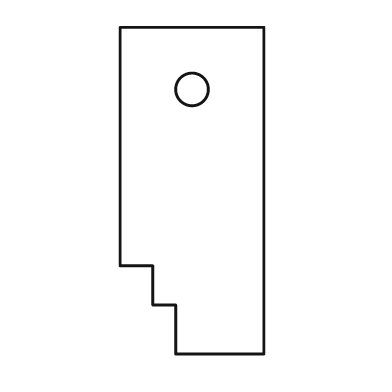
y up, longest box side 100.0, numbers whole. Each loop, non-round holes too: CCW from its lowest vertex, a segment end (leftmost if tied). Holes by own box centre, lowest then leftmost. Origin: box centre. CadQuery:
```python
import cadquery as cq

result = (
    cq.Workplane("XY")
    .moveTo(-5.0, -50.0)
    .lineTo(22.0, -50.0)
    .lineTo(22.0, 50.0)
    .lineTo(-22.0, 50.0)
    .lineTo(-22.0, -23.0)
    .lineTo(-12.0, -23.0)
    .lineTo(-12.0, -35.0)
    .lineTo(-5.0, -35.0)
    .close()
    .moveTo(0.0, 31.0)
    .circle(5.0)
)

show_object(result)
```